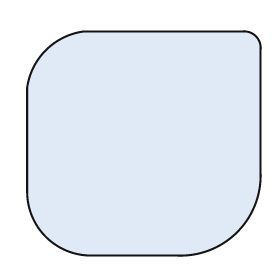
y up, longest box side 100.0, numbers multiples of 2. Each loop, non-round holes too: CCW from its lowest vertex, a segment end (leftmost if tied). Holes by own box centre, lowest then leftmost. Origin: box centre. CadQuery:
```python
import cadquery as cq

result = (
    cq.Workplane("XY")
    .moveTo(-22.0, -48.0)
    .lineTo(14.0, -48.0)
    .threePointArc((40.0, -38.0), (50.0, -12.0))
    .lineTo(50.0, 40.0)
    .threePointArc((48.0, 46.0), (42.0, 48.0))
    .lineTo(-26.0, 48.0)
    .threePointArc((-42.0, 40.0), (-50.0, 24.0))
    .lineTo(-50.0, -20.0)
    .threePointArc((-42.0, -40.0), (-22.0, -48.0))
    .close()
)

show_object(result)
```